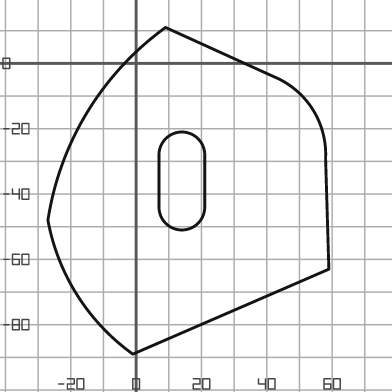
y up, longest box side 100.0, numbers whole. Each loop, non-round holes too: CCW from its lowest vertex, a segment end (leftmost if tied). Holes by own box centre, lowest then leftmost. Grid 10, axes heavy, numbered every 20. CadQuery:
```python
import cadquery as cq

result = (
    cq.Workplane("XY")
    .moveTo(-1.0, -89.0)
    .lineTo(59.0, -63.0)
    .lineTo(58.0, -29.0)
    .threePointArc((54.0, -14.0), (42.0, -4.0))
    .lineTo(9.0, 11.0)
    .threePointArc((-15.0, -15.0), (-27.0, -48.0))
    .threePointArc((-18.0, -71.0), (-1.0, -89.0))
    .close()
    .moveTo(7.0, -44.0)
    .threePointArc((14.0, -51.0), (21.0, -44.0))
    .lineTo(21.0, -28.0)
    .threePointArc((14.0, -21.0), (7.0, -28.0))
    .close()
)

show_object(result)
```